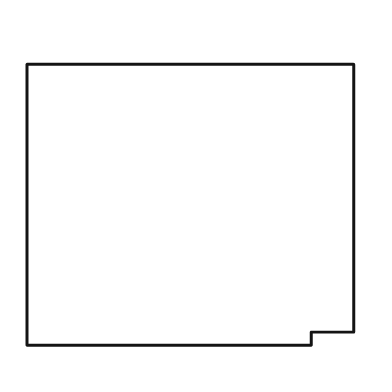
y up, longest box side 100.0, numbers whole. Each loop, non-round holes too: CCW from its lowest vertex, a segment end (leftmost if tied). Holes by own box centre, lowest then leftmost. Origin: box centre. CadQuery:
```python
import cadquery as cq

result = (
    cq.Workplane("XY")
    .moveTo(-50.0, -43.0)
    .lineTo(37.0, -43.0)
    .lineTo(37.0, -39.0)
    .lineTo(50.0, -39.0)
    .lineTo(50.0, 43.0)
    .lineTo(-50.0, 43.0)
    .close()
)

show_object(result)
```